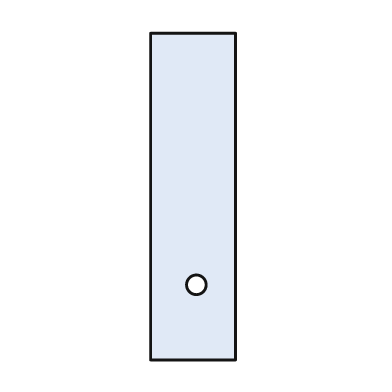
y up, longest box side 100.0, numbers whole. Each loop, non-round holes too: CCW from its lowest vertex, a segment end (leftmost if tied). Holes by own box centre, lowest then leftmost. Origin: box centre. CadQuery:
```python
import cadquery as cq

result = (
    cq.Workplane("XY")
    .moveTo(-13.0, -50.0)
    .lineTo(13.0, -50.0)
    .lineTo(13.0, 50.0)
    .lineTo(-13.0, 50.0)
    .close()
    .moveTo(1.0, -27.0)
    .circle(3.0)
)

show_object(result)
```